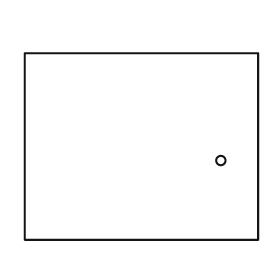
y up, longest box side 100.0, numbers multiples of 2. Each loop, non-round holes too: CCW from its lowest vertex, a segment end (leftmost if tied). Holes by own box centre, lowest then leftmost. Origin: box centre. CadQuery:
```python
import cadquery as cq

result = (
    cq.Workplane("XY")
    .moveTo(-50.0, -40.0)
    .lineTo(50.0, -40.0)
    .lineTo(50.0, 40.0)
    .lineTo(-50.0, 40.0)
    .close()
    .moveTo(34.0, -6.0)
    .circle(2.0)
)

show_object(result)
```